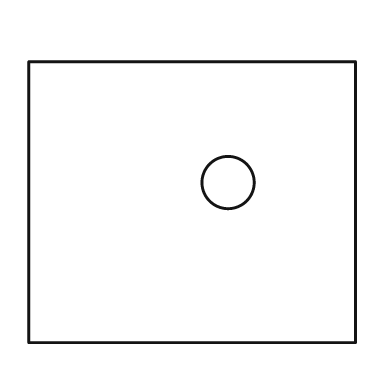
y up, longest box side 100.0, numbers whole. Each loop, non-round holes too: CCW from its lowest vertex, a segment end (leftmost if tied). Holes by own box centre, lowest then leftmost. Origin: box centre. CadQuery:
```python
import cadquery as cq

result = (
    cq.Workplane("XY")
    .moveTo(-50.0, -43.0)
    .lineTo(50.0, -43.0)
    .lineTo(50.0, 43.0)
    .lineTo(-50.0, 43.0)
    .close()
    .moveTo(11.0, 6.0)
    .circle(8.0)
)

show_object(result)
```